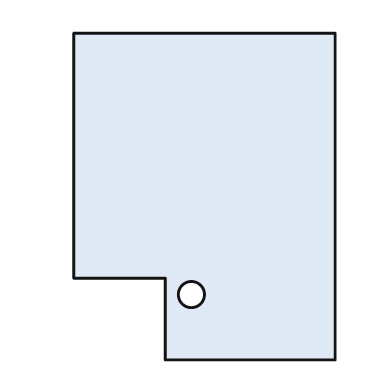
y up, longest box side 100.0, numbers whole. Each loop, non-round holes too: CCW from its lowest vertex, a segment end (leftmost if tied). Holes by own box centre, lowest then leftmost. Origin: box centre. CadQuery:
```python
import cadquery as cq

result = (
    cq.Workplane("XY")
    .moveTo(-12.0, -50.0)
    .lineTo(40.0, -50.0)
    .lineTo(40.0, 50.0)
    .lineTo(-40.0, 50.0)
    .lineTo(-40.0, -25.0)
    .lineTo(-12.0, -25.0)
    .close()
    .moveTo(-4.0, -30.0)
    .circle(4.0)
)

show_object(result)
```